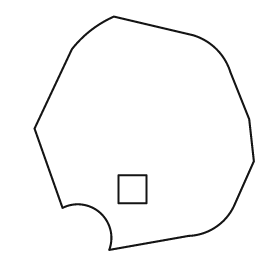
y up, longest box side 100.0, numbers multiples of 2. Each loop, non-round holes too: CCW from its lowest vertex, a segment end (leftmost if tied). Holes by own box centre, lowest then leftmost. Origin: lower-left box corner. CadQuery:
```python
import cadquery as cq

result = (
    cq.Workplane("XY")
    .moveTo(32.0, 0.0)
    .lineTo(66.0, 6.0)
    .threePointArc((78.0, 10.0), (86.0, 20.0))
    .lineTo(94.0, 38.0)
    .lineTo(92.0, 56.0)
    .lineTo(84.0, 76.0)
    .threePointArc((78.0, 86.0), (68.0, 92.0))
    .lineTo(34.0, 100.0)
    .threePointArc((24.0, 94.0), (16.0, 86.0))
    .lineTo(0.0, 52.0)
    .lineTo(12.0, 18.0)
    .threePointArc((28.0, 16.0), (32.0, 0.0))
    .close()
    .moveTo(36.0, 20.0)
    .lineTo(48.0, 20.0)
    .lineTo(48.0, 32.0)
    .lineTo(36.0, 32.0)
    .close()
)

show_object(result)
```